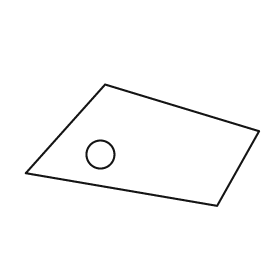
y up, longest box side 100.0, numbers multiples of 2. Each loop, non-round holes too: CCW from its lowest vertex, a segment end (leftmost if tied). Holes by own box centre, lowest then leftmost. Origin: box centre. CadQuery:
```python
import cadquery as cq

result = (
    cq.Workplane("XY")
    .moveTo(32.0, -26.0)
    .lineTo(50.0, 6.0)
    .lineTo(-16.0, 26.0)
    .lineTo(-50.0, -12.0)
    .close()
    .moveTo(-18.0, -4.0)
    .circle(6.0)
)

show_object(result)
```